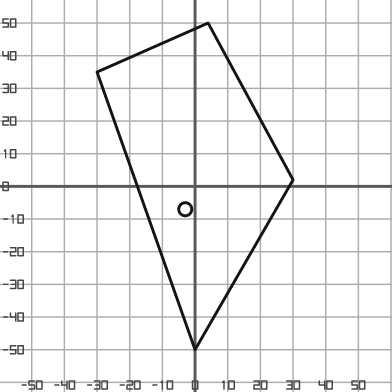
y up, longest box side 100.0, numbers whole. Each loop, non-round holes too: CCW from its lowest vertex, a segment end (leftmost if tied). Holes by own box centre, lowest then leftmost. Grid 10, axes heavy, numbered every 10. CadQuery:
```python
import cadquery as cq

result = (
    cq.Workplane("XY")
    .moveTo(0.0, -50.0)
    .lineTo(30.0, 2.0)
    .lineTo(4.0, 50.0)
    .lineTo(-30.0, 35.0)
    .close()
    .moveTo(-3.0, -7.0)
    .circle(2.0)
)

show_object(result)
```